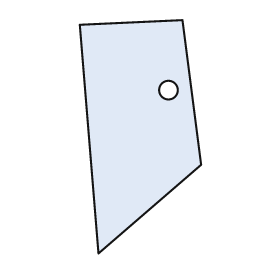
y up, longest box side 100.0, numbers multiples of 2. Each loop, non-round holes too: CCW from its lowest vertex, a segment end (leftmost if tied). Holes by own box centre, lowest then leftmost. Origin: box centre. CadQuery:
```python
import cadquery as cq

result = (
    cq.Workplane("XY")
    .moveTo(-18.0, -50.0)
    .lineTo(26.0, -12.0)
    .lineTo(18.0, 50.0)
    .lineTo(-26.0, 48.0)
    .close()
    .moveTo(12.0, 20.0)
    .circle(4.0)
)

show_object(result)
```